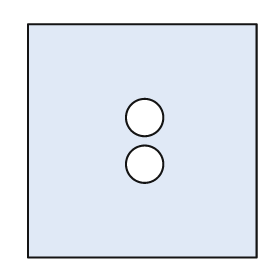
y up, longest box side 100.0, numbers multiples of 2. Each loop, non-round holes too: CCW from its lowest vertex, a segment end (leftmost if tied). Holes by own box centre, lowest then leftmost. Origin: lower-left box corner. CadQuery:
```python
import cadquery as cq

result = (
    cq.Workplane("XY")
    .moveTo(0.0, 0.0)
    .lineTo(98.0, 0.0)
    .lineTo(98.0, 100.0)
    .lineTo(0.0, 100.0)
    .close()
    .moveTo(50.0, 40.0)
    .circle(8.0)
    .moveTo(50.0, 60.0)
    .circle(8.0)
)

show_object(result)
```